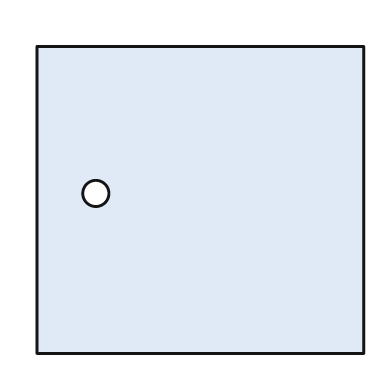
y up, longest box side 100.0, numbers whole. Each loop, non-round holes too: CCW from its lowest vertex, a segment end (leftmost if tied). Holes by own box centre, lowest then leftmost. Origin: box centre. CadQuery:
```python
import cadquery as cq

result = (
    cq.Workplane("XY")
    .moveTo(-50.0, -47.0)
    .lineTo(50.0, -47.0)
    .lineTo(50.0, 47.0)
    .lineTo(-50.0, 47.0)
    .close()
    .moveTo(-32.0, 2.0)
    .circle(4.0)
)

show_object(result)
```